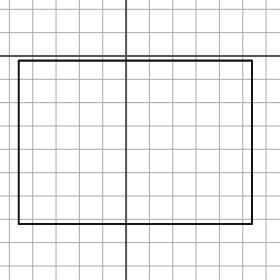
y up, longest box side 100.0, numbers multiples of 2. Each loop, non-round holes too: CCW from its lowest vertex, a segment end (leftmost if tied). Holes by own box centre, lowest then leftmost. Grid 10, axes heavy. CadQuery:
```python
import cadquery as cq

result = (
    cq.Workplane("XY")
    .moveTo(-46.0, -72.0)
    .lineTo(54.0, -72.0)
    .lineTo(54.0, -2.0)
    .lineTo(-46.0, -2.0)
    .close()
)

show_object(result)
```